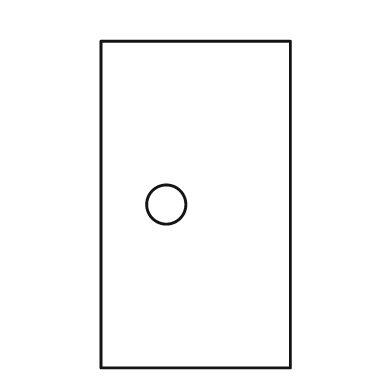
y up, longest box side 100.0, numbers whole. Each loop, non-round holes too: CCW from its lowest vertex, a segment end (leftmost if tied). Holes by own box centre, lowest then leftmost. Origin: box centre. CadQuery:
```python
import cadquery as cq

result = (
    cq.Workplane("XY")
    .moveTo(-29.0, -50.0)
    .lineTo(29.0, -50.0)
    .lineTo(29.0, 50.0)
    .lineTo(-29.0, 50.0)
    .close()
    .moveTo(-9.0, 0.0)
    .circle(6.0)
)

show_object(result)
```